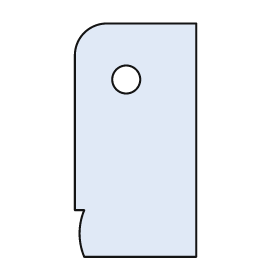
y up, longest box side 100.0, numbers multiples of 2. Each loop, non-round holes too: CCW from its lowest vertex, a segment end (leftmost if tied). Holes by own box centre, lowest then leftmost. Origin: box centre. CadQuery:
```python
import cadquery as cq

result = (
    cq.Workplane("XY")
    .moveTo(-22.0, -50.0)
    .lineTo(26.0, -50.0)
    .lineTo(26.0, 50.0)
    .lineTo(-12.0, 50.0)
    .threePointArc((-22.0, 46.0), (-26.0, 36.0))
    .lineTo(-26.0, -30.0)
    .lineTo(-22.0, -30.0)
    .threePointArc((-24.0, -40.0), (-22.0, -50.0))
    .close()
    .moveTo(-4.0, 26.0)
    .circle(6.0)
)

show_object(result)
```